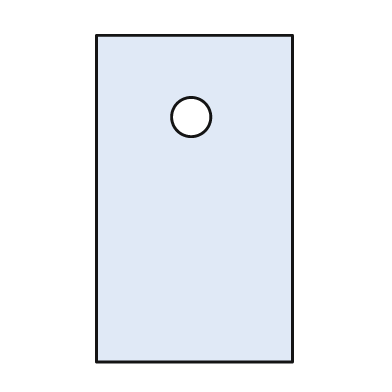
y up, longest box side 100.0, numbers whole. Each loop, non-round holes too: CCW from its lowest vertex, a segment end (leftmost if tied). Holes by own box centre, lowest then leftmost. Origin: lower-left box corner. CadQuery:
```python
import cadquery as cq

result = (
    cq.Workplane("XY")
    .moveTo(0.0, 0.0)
    .lineTo(60.0, 0.0)
    .lineTo(60.0, 100.0)
    .lineTo(0.0, 100.0)
    .close()
    .moveTo(29.0, 75.0)
    .circle(6.0)
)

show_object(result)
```